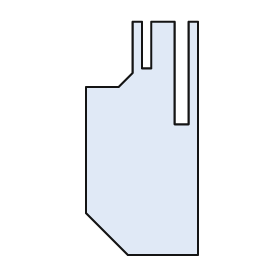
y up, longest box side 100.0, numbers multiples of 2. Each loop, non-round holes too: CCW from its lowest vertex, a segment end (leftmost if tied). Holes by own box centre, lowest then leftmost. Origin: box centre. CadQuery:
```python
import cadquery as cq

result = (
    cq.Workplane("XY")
    .moveTo(-6.0, -50.0)
    .lineTo(24.0, -50.0)
    .lineTo(24.0, 50.0)
    .lineTo(20.0, 50.0)
    .lineTo(20.0, 6.0)
    .lineTo(14.0, 6.0)
    .lineTo(14.0, 50.0)
    .lineTo(4.0, 50.0)
    .lineTo(4.0, 30.0)
    .lineTo(0.0, 30.0)
    .lineTo(0.0, 50.0)
    .lineTo(-4.0, 50.0)
    .lineTo(-4.0, 28.0)
    .lineTo(-10.0, 22.0)
    .lineTo(-24.0, 22.0)
    .lineTo(-24.0, -32.0)
    .close()
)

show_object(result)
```